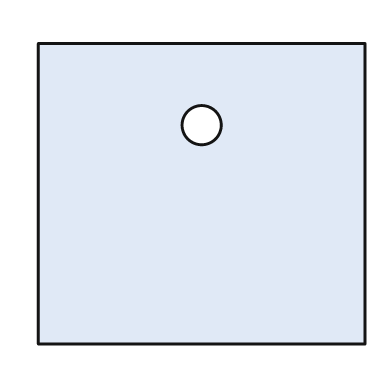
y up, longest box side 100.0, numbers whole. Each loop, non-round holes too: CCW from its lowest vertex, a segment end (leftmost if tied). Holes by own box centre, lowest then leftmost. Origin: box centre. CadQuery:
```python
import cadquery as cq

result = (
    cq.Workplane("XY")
    .moveTo(-50.0, -46.0)
    .lineTo(50.0, -46.0)
    .lineTo(50.0, 46.0)
    .lineTo(-50.0, 46.0)
    .close()
    .moveTo(0.0, 21.0)
    .circle(6.0)
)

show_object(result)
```